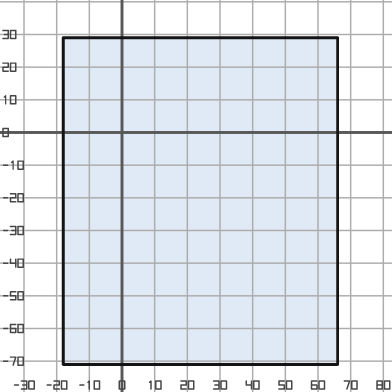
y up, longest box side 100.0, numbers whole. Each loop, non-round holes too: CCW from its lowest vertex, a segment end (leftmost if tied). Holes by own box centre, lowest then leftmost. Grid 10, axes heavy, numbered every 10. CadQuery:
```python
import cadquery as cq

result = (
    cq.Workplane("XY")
    .moveTo(-18.0, -71.0)
    .lineTo(66.0, -71.0)
    .lineTo(66.0, 29.0)
    .lineTo(-18.0, 29.0)
    .close()
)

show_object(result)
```